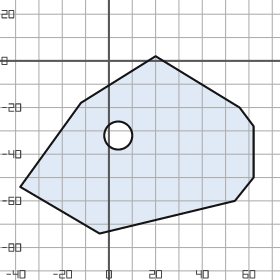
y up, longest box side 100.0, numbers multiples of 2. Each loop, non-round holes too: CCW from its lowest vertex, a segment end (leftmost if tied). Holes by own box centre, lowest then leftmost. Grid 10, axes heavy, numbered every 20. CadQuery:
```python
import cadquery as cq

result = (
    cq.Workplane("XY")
    .moveTo(-4.0, -74.0)
    .lineTo(54.0, -60.0)
    .lineTo(62.0, -50.0)
    .lineTo(62.0, -28.0)
    .lineTo(56.0, -20.0)
    .lineTo(20.0, 2.0)
    .lineTo(-12.0, -18.0)
    .lineTo(-38.0, -54.0)
    .close()
    .moveTo(4.0, -32.0)
    .circle(6.0)
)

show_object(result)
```